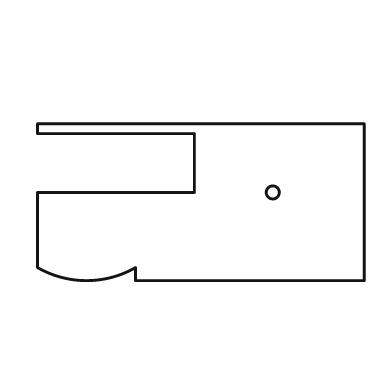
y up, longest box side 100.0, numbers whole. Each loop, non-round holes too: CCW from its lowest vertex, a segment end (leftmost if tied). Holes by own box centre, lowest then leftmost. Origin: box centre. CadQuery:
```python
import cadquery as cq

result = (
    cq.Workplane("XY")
    .moveTo(-20.0, -24.0)
    .lineTo(50.0, -24.0)
    .lineTo(50.0, 24.0)
    .lineTo(-50.0, 24.0)
    .lineTo(-50.0, 21.0)
    .lineTo(-2.0, 21.0)
    .lineTo(-2.0, 3.0)
    .lineTo(-50.0, 3.0)
    .lineTo(-50.0, -20.0)
    .threePointArc((-35.0, -24.0), (-20.0, -20.0))
    .close()
    .moveTo(22.0, 3.0)
    .circle(2.0)
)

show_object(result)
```